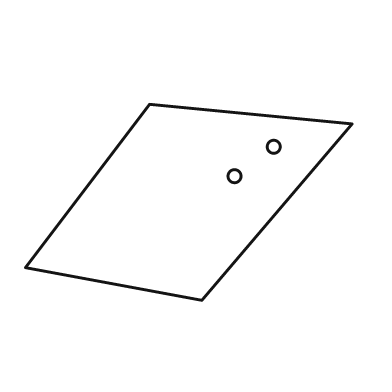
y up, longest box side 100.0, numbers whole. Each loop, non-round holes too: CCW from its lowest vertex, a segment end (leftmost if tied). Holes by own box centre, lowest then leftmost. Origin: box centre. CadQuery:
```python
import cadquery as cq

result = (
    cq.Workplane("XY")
    .moveTo(4.0, -30.0)
    .lineTo(50.0, 24.0)
    .lineTo(-12.0, 30.0)
    .lineTo(-50.0, -20.0)
    .close()
    .moveTo(14.0, 8.0)
    .circle(2.0)
    .moveTo(26.0, 17.0)
    .circle(2.0)
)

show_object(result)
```